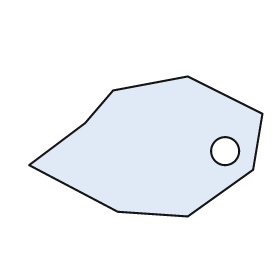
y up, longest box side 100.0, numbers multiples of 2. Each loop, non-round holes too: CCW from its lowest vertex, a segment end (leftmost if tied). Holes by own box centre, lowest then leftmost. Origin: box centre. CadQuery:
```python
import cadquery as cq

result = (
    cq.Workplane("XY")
    .moveTo(18.0, -30.0)
    .lineTo(46.0, -10.0)
    .lineTo(50.0, 14.0)
    .lineTo(18.0, 30.0)
    .lineTo(-14.0, 24.0)
    .lineTo(-26.0, 10.0)
    .lineTo(-50.0, -8.0)
    .lineTo(-12.0, -28.0)
    .close()
    .moveTo(34.0, -2.0)
    .circle(6.0)
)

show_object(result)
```